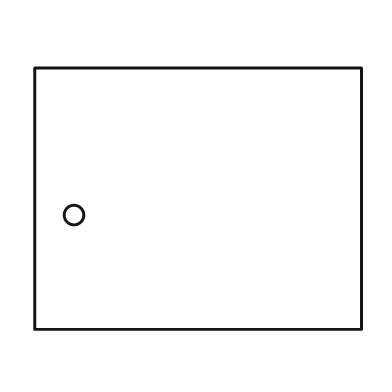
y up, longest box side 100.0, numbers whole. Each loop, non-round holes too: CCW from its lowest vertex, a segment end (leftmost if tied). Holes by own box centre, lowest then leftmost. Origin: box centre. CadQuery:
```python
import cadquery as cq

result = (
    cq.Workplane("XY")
    .moveTo(-50.0, -40.0)
    .lineTo(50.0, -40.0)
    .lineTo(50.0, 40.0)
    .lineTo(-50.0, 40.0)
    .close()
    .moveTo(-38.0, -5.0)
    .circle(3.0)
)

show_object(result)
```